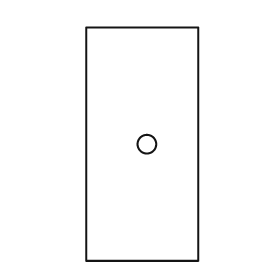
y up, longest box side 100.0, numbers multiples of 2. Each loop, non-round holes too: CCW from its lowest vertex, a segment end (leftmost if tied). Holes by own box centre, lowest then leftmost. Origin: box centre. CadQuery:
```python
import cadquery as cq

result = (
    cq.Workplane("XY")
    .moveTo(-24.0, -50.0)
    .lineTo(24.0, -50.0)
    .lineTo(24.0, 50.0)
    .lineTo(-24.0, 50.0)
    .close()
    .moveTo(2.0, 0.0)
    .circle(4.0)
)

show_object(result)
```